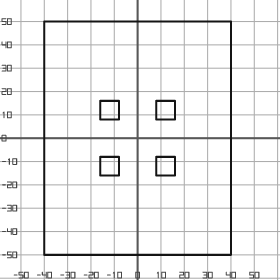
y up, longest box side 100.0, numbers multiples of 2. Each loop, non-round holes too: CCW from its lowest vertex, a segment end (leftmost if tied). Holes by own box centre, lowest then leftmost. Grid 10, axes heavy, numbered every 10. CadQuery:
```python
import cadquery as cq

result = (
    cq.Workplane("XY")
    .moveTo(-40.0, -50.0)
    .lineTo(40.0, -50.0)
    .lineTo(40.0, 50.0)
    .lineTo(-40.0, 50.0)
    .close()
    .moveTo(-16.0, -16.0)
    .lineTo(-8.0, -16.0)
    .lineTo(-8.0, -8.0)
    .lineTo(-16.0, -8.0)
    .close()
    .moveTo(8.0, -16.0)
    .lineTo(16.0, -16.0)
    .lineTo(16.0, -8.0)
    .lineTo(8.0, -8.0)
    .close()
    .moveTo(-16.0, 8.0)
    .lineTo(-8.0, 8.0)
    .lineTo(-8.0, 16.0)
    .lineTo(-16.0, 16.0)
    .close()
    .moveTo(8.0, 8.0)
    .lineTo(16.0, 8.0)
    .lineTo(16.0, 16.0)
    .lineTo(8.0, 16.0)
    .close()
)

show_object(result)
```